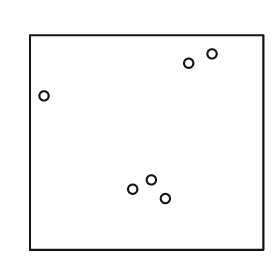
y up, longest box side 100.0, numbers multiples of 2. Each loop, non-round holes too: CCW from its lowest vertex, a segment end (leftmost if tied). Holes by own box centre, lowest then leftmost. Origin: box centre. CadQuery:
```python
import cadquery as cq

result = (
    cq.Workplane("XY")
    .moveTo(-50.0, -46.0)
    .lineTo(50.0, -46.0)
    .lineTo(50.0, 46.0)
    .lineTo(-50.0, 46.0)
    .close()
    .moveTo(8.0, -24.0)
    .circle(2.0)
    .moveTo(-6.0, -20.0)
    .circle(2.0)
    .moveTo(2.0, -16.0)
    .circle(2.0)
    .moveTo(-44.0, 20.0)
    .circle(2.0)
    .moveTo(18.0, 34.0)
    .circle(2.0)
    .moveTo(28.0, 38.0)
    .circle(2.0)
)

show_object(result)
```